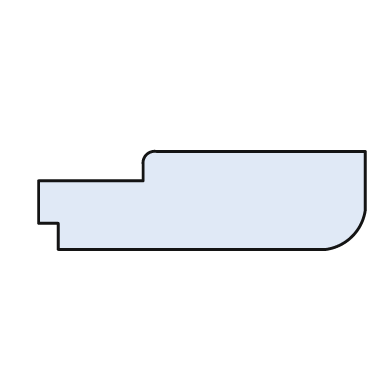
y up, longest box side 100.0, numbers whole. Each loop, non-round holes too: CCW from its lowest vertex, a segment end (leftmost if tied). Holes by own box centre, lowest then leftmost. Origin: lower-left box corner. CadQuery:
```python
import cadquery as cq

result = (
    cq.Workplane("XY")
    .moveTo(6.0, 0.0)
    .lineTo(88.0, 0.0)
    .threePointArc((96.0, 4.0), (100.0, 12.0))
    .lineTo(100.0, 30.0)
    .lineTo(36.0, 30.0)
    .threePointArc((33.0, 29.0), (32.0, 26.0))
    .lineTo(32.0, 21.0)
    .lineTo(0.0, 21.0)
    .lineTo(0.0, 8.0)
    .lineTo(6.0, 8.0)
    .close()
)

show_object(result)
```